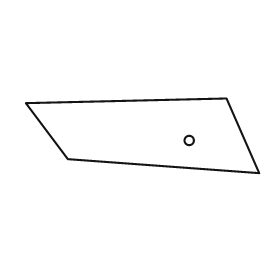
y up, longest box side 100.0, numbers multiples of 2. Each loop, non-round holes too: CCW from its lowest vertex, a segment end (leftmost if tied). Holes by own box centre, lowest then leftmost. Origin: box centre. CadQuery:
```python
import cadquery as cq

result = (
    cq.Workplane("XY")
    .moveTo(50.0, -16.0)
    .lineTo(36.0, 16.0)
    .lineTo(-50.0, 14.0)
    .lineTo(-32.0, -10.0)
    .close()
    .moveTo(20.0, -2.0)
    .circle(2.0)
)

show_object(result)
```